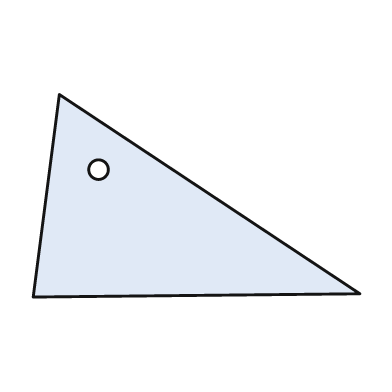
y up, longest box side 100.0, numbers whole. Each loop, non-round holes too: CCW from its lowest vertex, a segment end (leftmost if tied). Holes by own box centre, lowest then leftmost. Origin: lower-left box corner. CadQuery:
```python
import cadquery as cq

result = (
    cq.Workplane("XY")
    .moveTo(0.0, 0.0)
    .lineTo(100.0, 1.0)
    .lineTo(8.0, 62.0)
    .close()
    .moveTo(20.0, 39.0)
    .circle(3.0)
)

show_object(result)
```